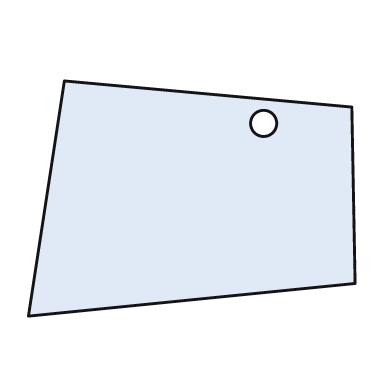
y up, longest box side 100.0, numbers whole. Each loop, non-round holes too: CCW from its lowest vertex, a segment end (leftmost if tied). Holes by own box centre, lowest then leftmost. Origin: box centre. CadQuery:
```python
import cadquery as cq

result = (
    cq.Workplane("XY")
    .moveTo(-50.0, -36.0)
    .lineTo(50.0, -26.0)
    .lineTo(49.0, 28.0)
    .lineTo(-39.0, 36.0)
    .close()
    .moveTo(22.0, 23.0)
    .circle(4.0)
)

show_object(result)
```